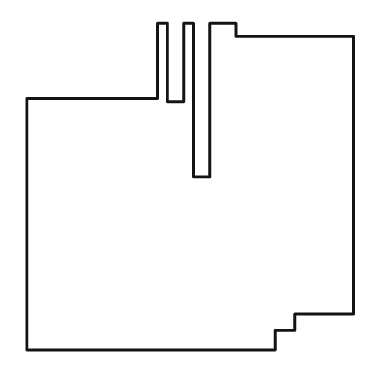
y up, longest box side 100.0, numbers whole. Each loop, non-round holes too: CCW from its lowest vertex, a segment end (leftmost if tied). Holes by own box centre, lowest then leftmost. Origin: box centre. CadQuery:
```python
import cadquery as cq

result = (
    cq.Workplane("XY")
    .moveTo(-50.0, -50.0)
    .lineTo(26.0, -50.0)
    .lineTo(26.0, -44.0)
    .lineTo(32.0, -44.0)
    .lineTo(32.0, -39.0)
    .lineTo(50.0, -39.0)
    .lineTo(50.0, 46.0)
    .lineTo(14.0, 46.0)
    .lineTo(14.0, 50.0)
    .lineTo(6.0, 50.0)
    .lineTo(6.0, 3.0)
    .lineTo(1.0, 3.0)
    .lineTo(1.0, 50.0)
    .lineTo(-2.0, 50.0)
    .lineTo(-2.0, 26.0)
    .lineTo(-7.0, 26.0)
    .lineTo(-7.0, 50.0)
    .lineTo(-10.0, 50.0)
    .lineTo(-10.0, 27.0)
    .lineTo(-50.0, 27.0)
    .close()
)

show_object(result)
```